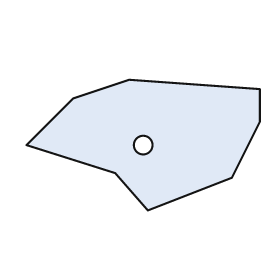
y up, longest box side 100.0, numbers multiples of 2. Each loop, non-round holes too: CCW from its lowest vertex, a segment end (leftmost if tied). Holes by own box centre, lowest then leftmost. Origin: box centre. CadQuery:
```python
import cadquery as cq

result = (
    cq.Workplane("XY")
    .moveTo(2.0, -28.0)
    .lineTo(38.0, -14.0)
    .lineTo(50.0, 10.0)
    .lineTo(50.0, 24.0)
    .lineTo(-6.0, 28.0)
    .lineTo(-30.0, 20.0)
    .lineTo(-50.0, 0.0)
    .lineTo(-12.0, -12.0)
    .close()
    .moveTo(0.0, 0.0)
    .circle(4.0)
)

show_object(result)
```